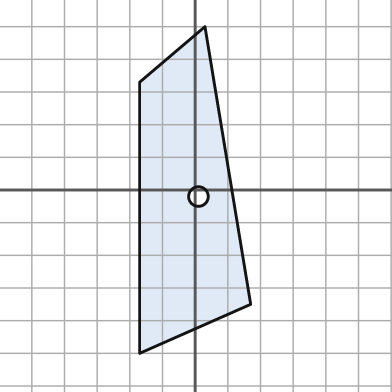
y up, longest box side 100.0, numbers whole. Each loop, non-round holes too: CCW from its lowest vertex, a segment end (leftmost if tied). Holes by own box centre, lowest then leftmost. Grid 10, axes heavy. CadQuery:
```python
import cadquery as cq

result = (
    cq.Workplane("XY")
    .moveTo(-17.0, -50.0)
    .lineTo(17.0, -35.0)
    .lineTo(3.0, 50.0)
    .lineTo(-17.0, 33.0)
    .close()
    .moveTo(1.0, -2.0)
    .circle(3.0)
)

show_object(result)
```